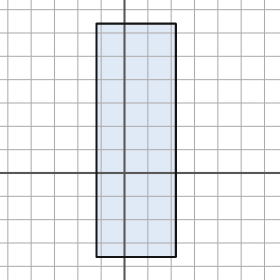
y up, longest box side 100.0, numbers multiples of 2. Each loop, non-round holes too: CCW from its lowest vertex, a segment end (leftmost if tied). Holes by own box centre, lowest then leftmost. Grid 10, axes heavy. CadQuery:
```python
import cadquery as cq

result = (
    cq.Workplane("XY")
    .moveTo(-12.0, -36.0)
    .lineTo(22.0, -36.0)
    .lineTo(22.0, 64.0)
    .lineTo(-12.0, 64.0)
    .close()
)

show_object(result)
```